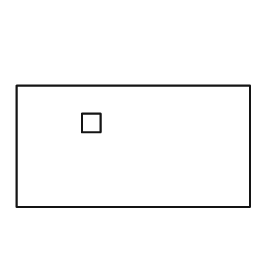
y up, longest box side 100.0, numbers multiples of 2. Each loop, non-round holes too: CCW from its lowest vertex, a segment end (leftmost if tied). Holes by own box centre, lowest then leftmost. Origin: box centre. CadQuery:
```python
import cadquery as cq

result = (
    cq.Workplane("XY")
    .moveTo(-50.0, -26.0)
    .lineTo(50.0, -26.0)
    .lineTo(50.0, 26.0)
    .lineTo(-50.0, 26.0)
    .close()
    .moveTo(-22.0, 6.0)
    .lineTo(-14.0, 6.0)
    .lineTo(-14.0, 14.0)
    .lineTo(-22.0, 14.0)
    .close()
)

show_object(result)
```